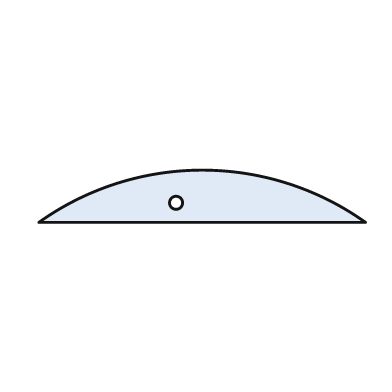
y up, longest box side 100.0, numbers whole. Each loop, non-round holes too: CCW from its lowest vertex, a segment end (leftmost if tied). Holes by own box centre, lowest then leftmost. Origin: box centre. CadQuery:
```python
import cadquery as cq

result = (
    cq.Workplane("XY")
    .moveTo(-50.0, -8.0)
    .lineTo(50.0, -8.0)
    .threePointArc((0.0, 8.0), (-50.0, -8.0))
    .close()
    .moveTo(-8.0, -2.0)
    .circle(2.0)
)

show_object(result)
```